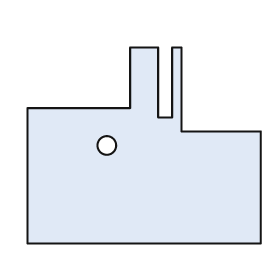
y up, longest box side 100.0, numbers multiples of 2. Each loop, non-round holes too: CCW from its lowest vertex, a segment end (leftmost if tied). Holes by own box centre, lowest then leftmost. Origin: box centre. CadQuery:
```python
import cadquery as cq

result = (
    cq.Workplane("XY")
    .moveTo(-50.0, -42.0)
    .lineTo(50.0, -42.0)
    .lineTo(50.0, 6.0)
    .lineTo(16.0, 6.0)
    .lineTo(16.0, 42.0)
    .lineTo(12.0, 42.0)
    .lineTo(12.0, 12.0)
    .lineTo(6.0, 12.0)
    .lineTo(6.0, 42.0)
    .lineTo(-6.0, 42.0)
    .lineTo(-6.0, 16.0)
    .lineTo(-50.0, 16.0)
    .close()
    .moveTo(-16.0, 0.0)
    .circle(4.0)
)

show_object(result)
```